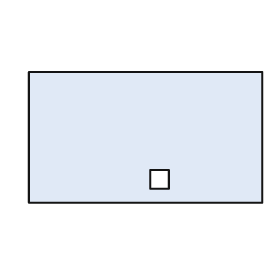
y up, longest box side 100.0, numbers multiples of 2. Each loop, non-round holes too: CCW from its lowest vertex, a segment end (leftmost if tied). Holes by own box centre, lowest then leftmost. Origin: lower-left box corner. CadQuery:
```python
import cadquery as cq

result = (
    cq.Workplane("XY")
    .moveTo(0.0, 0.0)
    .lineTo(100.0, 0.0)
    .lineTo(100.0, 56.0)
    .lineTo(0.0, 56.0)
    .close()
    .moveTo(52.0, 6.0)
    .lineTo(60.0, 6.0)
    .lineTo(60.0, 14.0)
    .lineTo(52.0, 14.0)
    .close()
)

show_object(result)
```